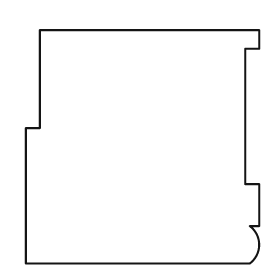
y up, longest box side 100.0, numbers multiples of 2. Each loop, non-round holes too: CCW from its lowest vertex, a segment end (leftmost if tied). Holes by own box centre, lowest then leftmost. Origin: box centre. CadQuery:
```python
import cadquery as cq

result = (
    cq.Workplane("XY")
    .moveTo(-50.0, -50.0)
    .lineTo(46.0, -50.0)
    .threePointArc((50.0, -42.0), (46.0, -34.0))
    .lineTo(50.0, -34.0)
    .lineTo(50.0, -16.0)
    .lineTo(44.0, -16.0)
    .lineTo(44.0, 42.0)
    .lineTo(50.0, 42.0)
    .lineTo(50.0, 50.0)
    .lineTo(-44.0, 50.0)
    .lineTo(-44.0, 8.0)
    .lineTo(-50.0, 8.0)
    .close()
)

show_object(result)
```